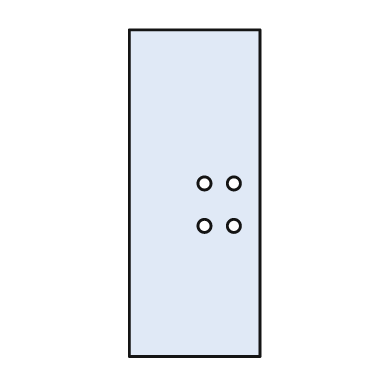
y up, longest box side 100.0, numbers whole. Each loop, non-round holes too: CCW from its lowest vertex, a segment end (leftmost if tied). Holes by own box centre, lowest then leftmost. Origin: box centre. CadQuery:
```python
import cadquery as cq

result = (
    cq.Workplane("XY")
    .moveTo(-20.0, -50.0)
    .lineTo(20.0, -50.0)
    .lineTo(20.0, 50.0)
    .lineTo(-20.0, 50.0)
    .close()
    .moveTo(3.0, -10.0)
    .circle(2.0)
    .moveTo(12.0, -10.0)
    .circle(2.0)
    .moveTo(3.0, 3.0)
    .circle(2.0)
    .moveTo(12.0, 3.0)
    .circle(2.0)
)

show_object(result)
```